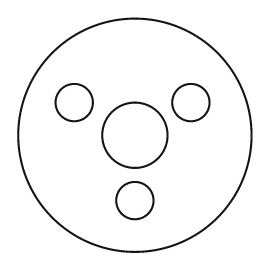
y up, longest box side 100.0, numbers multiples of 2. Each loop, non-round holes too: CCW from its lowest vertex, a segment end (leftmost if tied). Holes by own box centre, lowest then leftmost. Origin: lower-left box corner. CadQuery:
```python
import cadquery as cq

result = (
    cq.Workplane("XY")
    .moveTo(50.0, 50.0)
    .circle(50.0)
    .moveTo(50.0, 22.0)
    .circle(8.0)
    .moveTo(50.0, 50.0)
    .circle(14.0)
    .moveTo(24.0, 64.0)
    .circle(8.0)
    .moveTo(74.0, 64.0)
    .circle(8.0)
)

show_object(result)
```